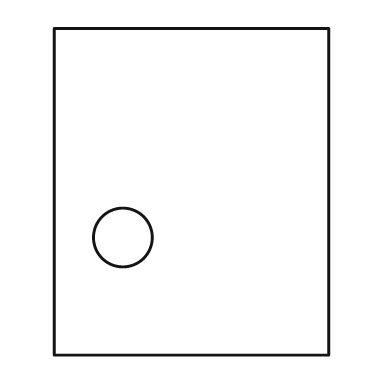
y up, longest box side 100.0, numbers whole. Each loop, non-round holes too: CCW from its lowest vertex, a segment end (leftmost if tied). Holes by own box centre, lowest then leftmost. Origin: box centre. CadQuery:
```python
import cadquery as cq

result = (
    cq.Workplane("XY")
    .moveTo(-42.0, -50.0)
    .lineTo(42.0, -50.0)
    .lineTo(42.0, 50.0)
    .lineTo(-42.0, 50.0)
    .close()
    .moveTo(-21.0, -14.0)
    .circle(9.0)
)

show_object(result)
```